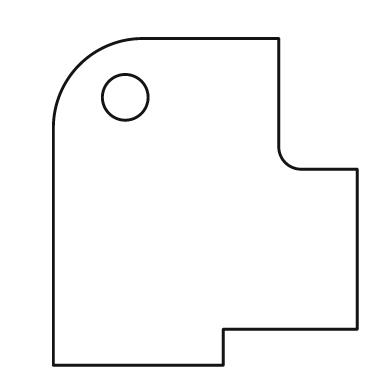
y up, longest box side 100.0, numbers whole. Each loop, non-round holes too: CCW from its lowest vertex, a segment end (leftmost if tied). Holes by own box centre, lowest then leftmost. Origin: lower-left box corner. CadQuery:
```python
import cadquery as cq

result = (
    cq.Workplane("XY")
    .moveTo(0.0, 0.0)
    .lineTo(52.0, 0.0)
    .lineTo(52.0, 11.0)
    .lineTo(93.0, 11.0)
    .lineTo(93.0, 60.0)
    .lineTo(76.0, 60.0)
    .threePointArc((71.0, 62.0), (69.0, 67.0))
    .lineTo(69.0, 100.0)
    .lineTo(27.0, 100.0)
    .threePointArc((8.0, 92.0), (0.0, 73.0))
    .close()
    .moveTo(22.0, 82.0)
    .circle(7.0)
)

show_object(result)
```